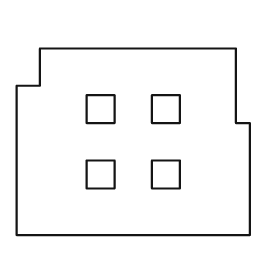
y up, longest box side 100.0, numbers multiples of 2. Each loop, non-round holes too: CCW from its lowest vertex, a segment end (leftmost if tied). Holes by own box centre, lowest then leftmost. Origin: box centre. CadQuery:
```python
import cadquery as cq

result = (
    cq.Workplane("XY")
    .moveTo(-50.0, -40.0)
    .lineTo(50.0, -40.0)
    .lineTo(50.0, 8.0)
    .lineTo(44.0, 8.0)
    .lineTo(44.0, 40.0)
    .lineTo(-40.0, 40.0)
    .lineTo(-40.0, 24.0)
    .lineTo(-50.0, 24.0)
    .close()
    .moveTo(-20.0, -20.0)
    .lineTo(-8.0, -20.0)
    .lineTo(-8.0, -8.0)
    .lineTo(-20.0, -8.0)
    .close()
    .moveTo(8.0, -20.0)
    .lineTo(20.0, -20.0)
    .lineTo(20.0, -8.0)
    .lineTo(8.0, -8.0)
    .close()
    .moveTo(-20.0, 8.0)
    .lineTo(-8.0, 8.0)
    .lineTo(-8.0, 20.0)
    .lineTo(-20.0, 20.0)
    .close()
    .moveTo(8.0, 8.0)
    .lineTo(20.0, 8.0)
    .lineTo(20.0, 20.0)
    .lineTo(8.0, 20.0)
    .close()
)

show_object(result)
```